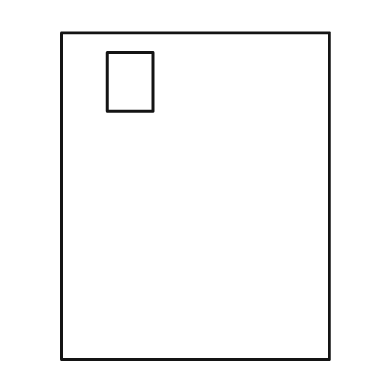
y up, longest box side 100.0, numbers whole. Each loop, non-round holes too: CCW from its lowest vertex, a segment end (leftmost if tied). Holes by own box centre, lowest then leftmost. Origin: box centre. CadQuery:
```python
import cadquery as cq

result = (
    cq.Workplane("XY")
    .moveTo(-41.0, -50.0)
    .lineTo(41.0, -50.0)
    .lineTo(41.0, 50.0)
    .lineTo(-41.0, 50.0)
    .close()
    .moveTo(-27.0, 26.0)
    .lineTo(-13.0, 26.0)
    .lineTo(-13.0, 44.0)
    .lineTo(-27.0, 44.0)
    .close()
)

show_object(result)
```